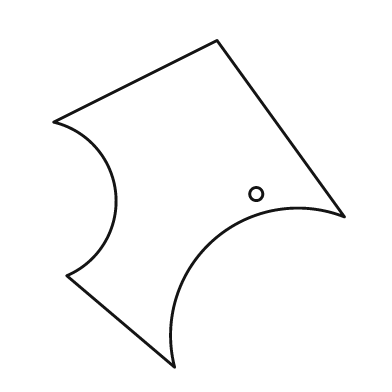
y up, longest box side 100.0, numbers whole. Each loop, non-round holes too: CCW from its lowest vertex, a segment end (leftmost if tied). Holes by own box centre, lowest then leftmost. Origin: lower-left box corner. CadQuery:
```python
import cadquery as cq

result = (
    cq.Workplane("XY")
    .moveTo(37.0, 0.0)
    .threePointArc((49.0, 39.0), (89.0, 46.0))
    .lineTo(50.0, 100.0)
    .lineTo(0.0, 75.0)
    .threePointArc((19.0, 53.0), (4.0, 28.0))
    .close()
    .moveTo(62.0, 53.0)
    .circle(2.0)
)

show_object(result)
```